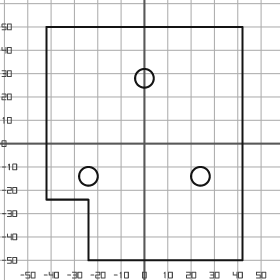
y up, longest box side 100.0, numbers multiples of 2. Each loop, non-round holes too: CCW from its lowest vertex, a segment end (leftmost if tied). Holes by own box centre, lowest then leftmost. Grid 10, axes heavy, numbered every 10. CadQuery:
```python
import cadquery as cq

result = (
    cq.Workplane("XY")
    .moveTo(-24.0, -50.0)
    .lineTo(42.0, -50.0)
    .lineTo(42.0, 50.0)
    .lineTo(-42.0, 50.0)
    .lineTo(-42.0, -24.0)
    .lineTo(-24.0, -24.0)
    .close()
    .moveTo(-24.0, -14.0)
    .circle(4.0)
    .moveTo(24.0, -14.0)
    .circle(4.0)
    .moveTo(0.0, 28.0)
    .circle(4.0)
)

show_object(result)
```